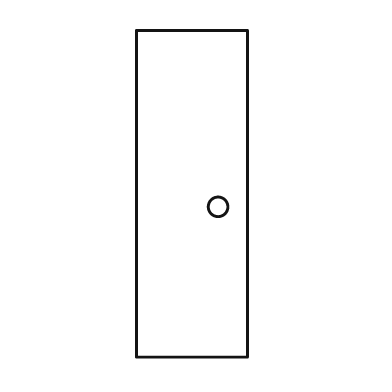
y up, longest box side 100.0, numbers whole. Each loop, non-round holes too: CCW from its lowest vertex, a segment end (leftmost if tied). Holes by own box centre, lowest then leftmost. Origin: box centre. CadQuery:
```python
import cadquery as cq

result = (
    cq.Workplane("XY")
    .moveTo(-17.0, -50.0)
    .lineTo(17.0, -50.0)
    .lineTo(17.0, 50.0)
    .lineTo(-17.0, 50.0)
    .close()
    .moveTo(8.0, -4.0)
    .circle(3.0)
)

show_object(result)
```